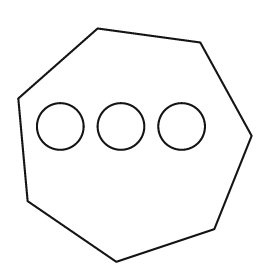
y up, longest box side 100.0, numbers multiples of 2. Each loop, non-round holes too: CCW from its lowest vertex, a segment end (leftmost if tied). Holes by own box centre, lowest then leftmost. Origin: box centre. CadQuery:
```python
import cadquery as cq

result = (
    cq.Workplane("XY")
    .moveTo(-8.0, -50.0)
    .lineTo(34.0, -36.0)
    .lineTo(50.0, 4.0)
    .lineTo(28.0, 44.0)
    .lineTo(-16.0, 50.0)
    .lineTo(-50.0, 20.0)
    .lineTo(-46.0, -24.0)
    .close()
    .moveTo(-32.0, 8.0)
    .circle(10.0)
    .moveTo(-6.0, 8.0)
    .circle(10.0)
    .moveTo(20.0, 8.0)
    .circle(10.0)
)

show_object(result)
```